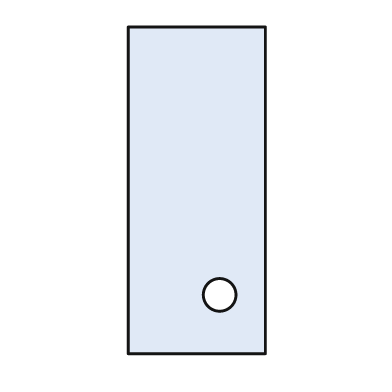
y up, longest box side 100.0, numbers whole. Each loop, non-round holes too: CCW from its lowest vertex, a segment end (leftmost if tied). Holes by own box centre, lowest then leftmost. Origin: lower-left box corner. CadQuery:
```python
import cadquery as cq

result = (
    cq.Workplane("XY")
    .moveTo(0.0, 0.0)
    .lineTo(42.0, 0.0)
    .lineTo(42.0, 100.0)
    .lineTo(0.0, 100.0)
    .close()
    .moveTo(28.0, 18.0)
    .circle(5.0)
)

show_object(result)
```